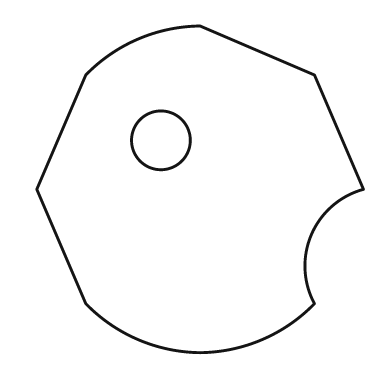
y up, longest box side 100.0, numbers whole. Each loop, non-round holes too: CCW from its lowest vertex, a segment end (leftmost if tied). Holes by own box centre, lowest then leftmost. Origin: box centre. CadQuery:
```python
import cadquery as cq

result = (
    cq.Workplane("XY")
    .moveTo(0.0, -50.0)
    .threePointArc((19.0, -46.0), (35.0, -35.0))
    .threePointArc((34.0, -14.0), (50.0, 0.0))
    .lineTo(35.0, 35.0)
    .lineTo(0.0, 50.0)
    .threePointArc((-19.0, 46.0), (-35.0, 35.0))
    .lineTo(-50.0, 0.0)
    .lineTo(-35.0, -35.0)
    .threePointArc((-19.0, -46.0), (0.0, -50.0))
    .close()
    .moveTo(-12.0, 15.0)
    .circle(9.0)
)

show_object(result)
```